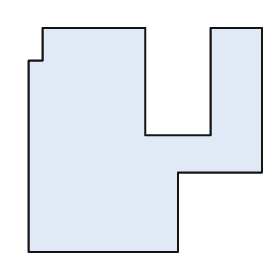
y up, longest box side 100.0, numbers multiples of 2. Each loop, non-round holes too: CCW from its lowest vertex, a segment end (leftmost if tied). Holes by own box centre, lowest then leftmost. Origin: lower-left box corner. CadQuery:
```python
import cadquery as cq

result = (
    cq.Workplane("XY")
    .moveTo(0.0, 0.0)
    .lineTo(64.0, 0.0)
    .lineTo(64.0, 34.0)
    .lineTo(100.0, 34.0)
    .lineTo(100.0, 96.0)
    .lineTo(78.0, 96.0)
    .lineTo(78.0, 50.0)
    .lineTo(50.0, 50.0)
    .lineTo(50.0, 96.0)
    .lineTo(6.0, 96.0)
    .lineTo(6.0, 82.0)
    .lineTo(0.0, 82.0)
    .close()
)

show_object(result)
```